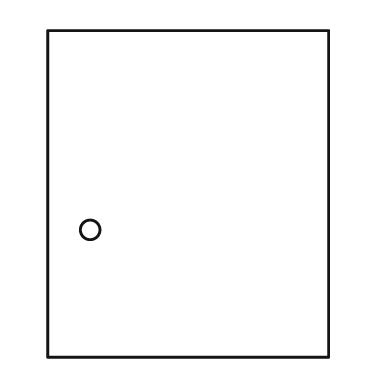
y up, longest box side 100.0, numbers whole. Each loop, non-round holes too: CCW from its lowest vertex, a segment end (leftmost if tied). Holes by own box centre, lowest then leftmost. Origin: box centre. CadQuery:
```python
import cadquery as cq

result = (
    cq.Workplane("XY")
    .moveTo(-43.0, -50.0)
    .lineTo(43.0, -50.0)
    .lineTo(43.0, 50.0)
    .lineTo(-43.0, 50.0)
    .close()
    .moveTo(-30.0, -11.0)
    .circle(3.0)
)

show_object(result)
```